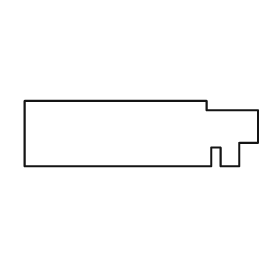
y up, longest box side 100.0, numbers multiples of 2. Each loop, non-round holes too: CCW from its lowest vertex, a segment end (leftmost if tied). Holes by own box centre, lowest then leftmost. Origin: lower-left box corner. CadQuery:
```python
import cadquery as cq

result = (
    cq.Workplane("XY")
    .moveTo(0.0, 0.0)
    .lineTo(80.0, 0.0)
    .lineTo(80.0, 8.0)
    .lineTo(84.0, 8.0)
    .lineTo(84.0, 0.0)
    .lineTo(92.0, 0.0)
    .lineTo(92.0, 10.0)
    .lineTo(100.0, 10.0)
    .lineTo(100.0, 24.0)
    .lineTo(78.0, 24.0)
    .lineTo(78.0, 28.0)
    .lineTo(0.0, 28.0)
    .close()
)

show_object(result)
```